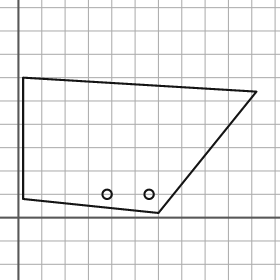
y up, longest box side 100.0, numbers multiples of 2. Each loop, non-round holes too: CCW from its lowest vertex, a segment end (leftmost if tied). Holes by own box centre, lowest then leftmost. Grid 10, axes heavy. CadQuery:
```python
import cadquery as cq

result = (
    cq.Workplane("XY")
    .moveTo(60.0, 2.0)
    .lineTo(102.0, 54.0)
    .lineTo(2.0, 60.0)
    .lineTo(2.0, 8.0)
    .close()
    .moveTo(38.0, 10.0)
    .circle(2.0)
    .moveTo(56.0, 10.0)
    .circle(2.0)
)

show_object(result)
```